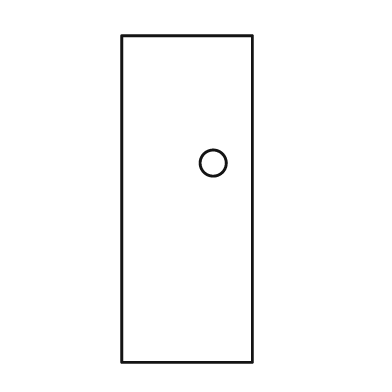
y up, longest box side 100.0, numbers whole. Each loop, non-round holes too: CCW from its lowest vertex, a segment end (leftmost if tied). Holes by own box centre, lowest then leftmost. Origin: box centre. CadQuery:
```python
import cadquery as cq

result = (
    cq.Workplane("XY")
    .moveTo(-20.0, -50.0)
    .lineTo(20.0, -50.0)
    .lineTo(20.0, 50.0)
    .lineTo(-20.0, 50.0)
    .close()
    .moveTo(8.0, 11.0)
    .circle(4.0)
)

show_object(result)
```